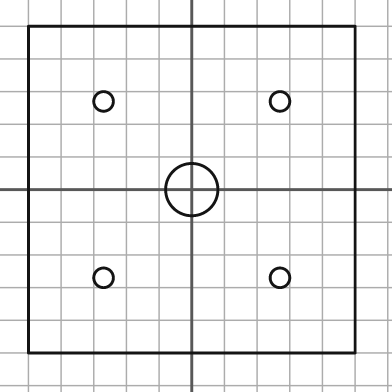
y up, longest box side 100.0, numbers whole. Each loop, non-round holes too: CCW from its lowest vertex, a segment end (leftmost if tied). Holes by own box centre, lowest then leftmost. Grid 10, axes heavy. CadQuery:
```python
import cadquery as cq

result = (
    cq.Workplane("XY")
    .moveTo(-50.0, -50.0)
    .lineTo(50.0, -50.0)
    .lineTo(50.0, 50.0)
    .lineTo(-50.0, 50.0)
    .close()
    .moveTo(-27.0, -27.0)
    .circle(3.0)
    .moveTo(27.0, -27.0)
    .circle(3.0)
    .moveTo(0.0, 0.0)
    .circle(8.0)
    .moveTo(-27.0, 27.0)
    .circle(3.0)
    .moveTo(27.0, 27.0)
    .circle(3.0)
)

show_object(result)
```